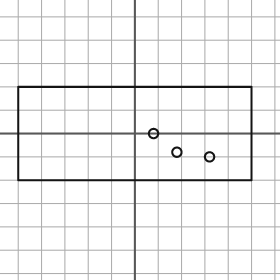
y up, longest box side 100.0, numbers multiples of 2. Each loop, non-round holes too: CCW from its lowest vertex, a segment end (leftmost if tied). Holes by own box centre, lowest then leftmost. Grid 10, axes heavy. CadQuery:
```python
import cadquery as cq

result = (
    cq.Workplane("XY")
    .moveTo(-50.0, -20.0)
    .lineTo(50.0, -20.0)
    .lineTo(50.0, 20.0)
    .lineTo(-50.0, 20.0)
    .close()
    .moveTo(32.0, -10.0)
    .circle(2.0)
    .moveTo(18.0, -8.0)
    .circle(2.0)
    .moveTo(8.0, 0.0)
    .circle(2.0)
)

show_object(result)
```